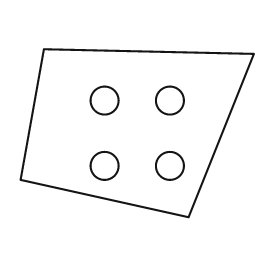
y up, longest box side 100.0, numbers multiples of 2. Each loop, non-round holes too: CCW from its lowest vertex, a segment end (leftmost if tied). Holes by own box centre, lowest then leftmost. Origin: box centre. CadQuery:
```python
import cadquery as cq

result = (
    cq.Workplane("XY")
    .moveTo(22.0, -36.0)
    .lineTo(50.0, 34.0)
    .lineTo(-40.0, 36.0)
    .lineTo(-50.0, -20.0)
    .close()
    .moveTo(-14.0, -14.0)
    .circle(6.0)
    .moveTo(14.0, -14.0)
    .circle(6.0)
    .moveTo(-14.0, 14.0)
    .circle(6.0)
    .moveTo(14.0, 14.0)
    .circle(6.0)
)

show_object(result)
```